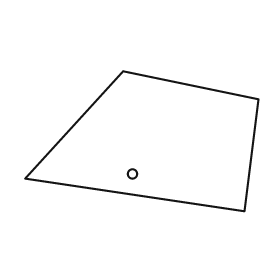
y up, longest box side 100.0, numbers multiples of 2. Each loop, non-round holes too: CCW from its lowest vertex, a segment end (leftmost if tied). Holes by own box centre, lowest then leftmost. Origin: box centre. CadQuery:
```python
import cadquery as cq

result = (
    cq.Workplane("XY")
    .moveTo(44.0, -30.0)
    .lineTo(50.0, 18.0)
    .lineTo(-8.0, 30.0)
    .lineTo(-50.0, -16.0)
    .close()
    .moveTo(-4.0, -14.0)
    .circle(2.0)
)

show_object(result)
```